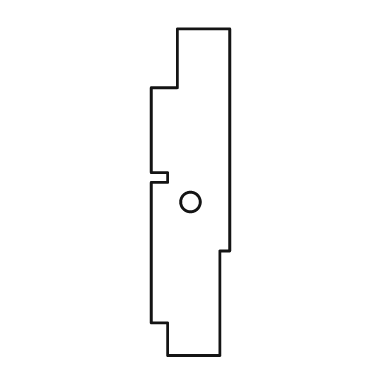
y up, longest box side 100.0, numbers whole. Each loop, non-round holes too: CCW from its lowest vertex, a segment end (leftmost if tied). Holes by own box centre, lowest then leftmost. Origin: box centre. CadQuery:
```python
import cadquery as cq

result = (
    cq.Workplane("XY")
    .moveTo(-7.0, -50.0)
    .lineTo(9.0, -50.0)
    .lineTo(9.0, -18.0)
    .lineTo(12.0, -18.0)
    .lineTo(12.0, 50.0)
    .lineTo(-4.0, 50.0)
    .lineTo(-4.0, 32.0)
    .lineTo(-12.0, 32.0)
    .lineTo(-12.0, 6.0)
    .lineTo(-7.0, 6.0)
    .lineTo(-7.0, 3.0)
    .lineTo(-12.0, 3.0)
    .lineTo(-12.0, -40.0)
    .lineTo(-7.0, -40.0)
    .close()
    .moveTo(0.0, -3.0)
    .circle(3.0)
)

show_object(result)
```